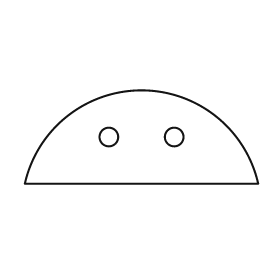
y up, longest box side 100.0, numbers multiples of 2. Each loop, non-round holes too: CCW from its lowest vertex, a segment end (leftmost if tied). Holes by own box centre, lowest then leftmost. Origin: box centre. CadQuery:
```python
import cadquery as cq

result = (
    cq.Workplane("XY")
    .moveTo(-50.0, -20.0)
    .lineTo(50.0, -20.0)
    .threePointArc((0.0, 20.0), (-50.0, -20.0))
    .close()
    .moveTo(-14.0, 0.0)
    .circle(4.0)
    .moveTo(14.0, 0.0)
    .circle(4.0)
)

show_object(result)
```